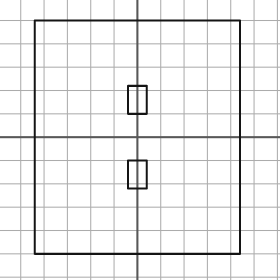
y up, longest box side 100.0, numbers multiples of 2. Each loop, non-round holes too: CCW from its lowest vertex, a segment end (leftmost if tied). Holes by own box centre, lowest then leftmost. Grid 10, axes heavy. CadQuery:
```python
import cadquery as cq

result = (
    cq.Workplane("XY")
    .moveTo(-44.0, -50.0)
    .lineTo(44.0, -50.0)
    .lineTo(44.0, 50.0)
    .lineTo(-44.0, 50.0)
    .close()
    .moveTo(-4.0, -22.0)
    .lineTo(4.0, -22.0)
    .lineTo(4.0, -10.0)
    .lineTo(-4.0, -10.0)
    .close()
    .moveTo(-4.0, 10.0)
    .lineTo(4.0, 10.0)
    .lineTo(4.0, 22.0)
    .lineTo(-4.0, 22.0)
    .close()
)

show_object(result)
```